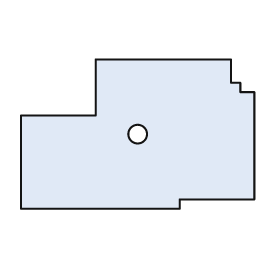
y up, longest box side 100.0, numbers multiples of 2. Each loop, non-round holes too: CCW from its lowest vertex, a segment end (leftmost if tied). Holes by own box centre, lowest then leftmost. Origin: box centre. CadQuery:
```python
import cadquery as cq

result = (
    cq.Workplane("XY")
    .moveTo(-50.0, -32.0)
    .lineTo(18.0, -32.0)
    .lineTo(18.0, -28.0)
    .lineTo(50.0, -28.0)
    .lineTo(50.0, 18.0)
    .lineTo(44.0, 18.0)
    .lineTo(44.0, 22.0)
    .lineTo(40.0, 22.0)
    .lineTo(40.0, 32.0)
    .lineTo(-18.0, 32.0)
    .lineTo(-18.0, 8.0)
    .lineTo(-50.0, 8.0)
    .close()
    .moveTo(0.0, 0.0)
    .circle(4.0)
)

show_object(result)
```